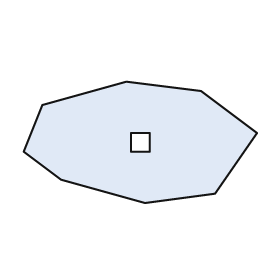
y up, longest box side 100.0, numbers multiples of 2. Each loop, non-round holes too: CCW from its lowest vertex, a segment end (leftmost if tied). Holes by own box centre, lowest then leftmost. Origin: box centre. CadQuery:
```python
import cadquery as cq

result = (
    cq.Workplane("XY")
    .moveTo(2.0, -26.0)
    .lineTo(32.0, -22.0)
    .lineTo(50.0, 4.0)
    .lineTo(26.0, 22.0)
    .lineTo(-6.0, 26.0)
    .lineTo(-42.0, 16.0)
    .lineTo(-50.0, -4.0)
    .lineTo(-34.0, -16.0)
    .close()
    .moveTo(-4.0, -4.0)
    .lineTo(4.0, -4.0)
    .lineTo(4.0, 4.0)
    .lineTo(-4.0, 4.0)
    .close()
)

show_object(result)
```